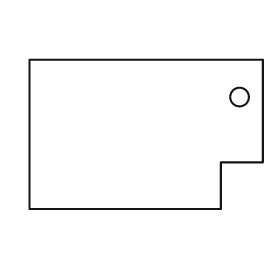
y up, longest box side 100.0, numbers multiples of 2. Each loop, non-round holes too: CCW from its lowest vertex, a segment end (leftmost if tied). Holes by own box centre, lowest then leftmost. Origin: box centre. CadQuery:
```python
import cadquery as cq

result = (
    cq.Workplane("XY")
    .moveTo(-50.0, -32.0)
    .lineTo(32.0, -32.0)
    .lineTo(32.0, -12.0)
    .lineTo(50.0, -12.0)
    .lineTo(50.0, 32.0)
    .lineTo(-50.0, 32.0)
    .close()
    .moveTo(40.0, 16.0)
    .circle(4.0)
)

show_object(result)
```